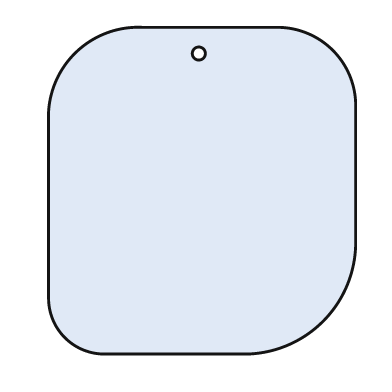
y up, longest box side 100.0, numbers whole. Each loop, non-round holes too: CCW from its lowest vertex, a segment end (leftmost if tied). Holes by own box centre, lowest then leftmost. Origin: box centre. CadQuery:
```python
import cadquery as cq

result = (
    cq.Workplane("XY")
    .moveTo(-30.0, -50.0)
    .lineTo(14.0, -50.0)
    .threePointArc((37.0, -40.0), (47.0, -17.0))
    .lineTo(47.0, 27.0)
    .threePointArc((40.0, 43.0), (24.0, 50.0))
    .lineTo(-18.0, 50.0)
    .threePointArc((-39.0, 42.0), (-47.0, 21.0))
    .lineTo(-47.0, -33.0)
    .threePointArc((-42.0, -45.0), (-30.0, -50.0))
    .close()
    .moveTo(-1.0, 42.0)
    .circle(2.0)
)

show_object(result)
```